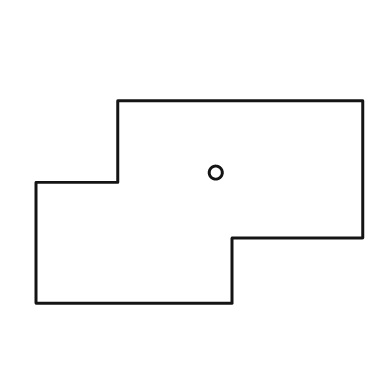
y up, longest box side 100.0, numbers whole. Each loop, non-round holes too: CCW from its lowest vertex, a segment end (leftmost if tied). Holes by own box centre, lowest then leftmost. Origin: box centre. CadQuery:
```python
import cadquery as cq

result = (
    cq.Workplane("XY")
    .moveTo(-50.0, -31.0)
    .lineTo(10.0, -31.0)
    .lineTo(10.0, -11.0)
    .lineTo(50.0, -11.0)
    .lineTo(50.0, 31.0)
    .lineTo(-25.0, 31.0)
    .lineTo(-25.0, 6.0)
    .lineTo(-50.0, 6.0)
    .close()
    .moveTo(5.0, 9.0)
    .circle(2.0)
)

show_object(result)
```